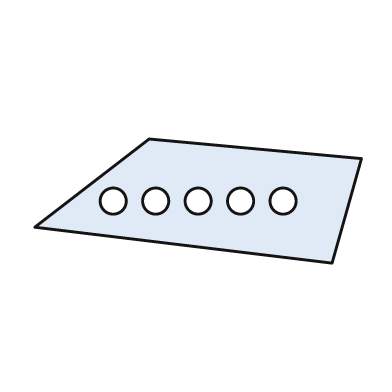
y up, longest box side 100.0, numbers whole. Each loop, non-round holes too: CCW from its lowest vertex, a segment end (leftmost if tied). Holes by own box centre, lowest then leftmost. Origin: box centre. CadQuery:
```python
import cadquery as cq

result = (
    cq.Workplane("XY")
    .moveTo(41.0, -19.0)
    .lineTo(50.0, 13.0)
    .lineTo(-15.0, 19.0)
    .lineTo(-50.0, -8.0)
    .close()
    .moveTo(-26.0, 0.0)
    .circle(4.0)
    .moveTo(-13.0, 0.0)
    .circle(4.0)
    .moveTo(0.0, 0.0)
    .circle(4.0)
    .moveTo(13.0, 0.0)
    .circle(4.0)
    .moveTo(26.0, 0.0)
    .circle(4.0)
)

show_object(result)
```